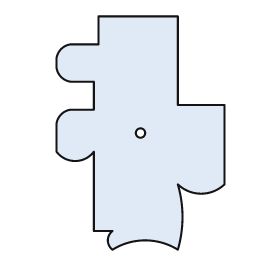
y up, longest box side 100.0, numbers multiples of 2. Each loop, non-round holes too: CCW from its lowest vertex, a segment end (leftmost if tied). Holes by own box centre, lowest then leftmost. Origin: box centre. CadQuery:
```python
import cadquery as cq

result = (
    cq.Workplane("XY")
    .moveTo(-12.0, -50.0)
    .threePointArc((2.0, -46.0), (16.0, -50.0))
    .threePointArc((18.0, -36.0), (16.0, -22.0))
    .threePointArc((26.0, -26.0), (36.0, -22.0))
    .lineTo(36.0, 12.0)
    .lineTo(16.0, 12.0)
    .lineTo(16.0, 50.0)
    .lineTo(-18.0, 50.0)
    .lineTo(-18.0, 38.0)
    .lineTo(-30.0, 38.0)
    .threePointArc((-34.0, 36.0), (-36.0, 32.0))
    .lineTo(-36.0, 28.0)
    .threePointArc((-34.0, 24.0), (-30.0, 22.0))
    .lineTo(-20.0, 22.0)
    .lineTo(-20.0, 10.0)
    .lineTo(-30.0, 10.0)
    .threePointArc((-34.0, 8.0), (-36.0, 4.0))
    .lineTo(-36.0, -8.0)
    .threePointArc((-28.0, -12.0), (-20.0, -8.0))
    .lineTo(-20.0, -42.0)
    .lineTo(-12.0, -42.0)
    .threePointArc((-14.0, -46.0), (-12.0, -50.0))
    .close()
    .moveTo(0.0, 0.0)
    .circle(2.0)
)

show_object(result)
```